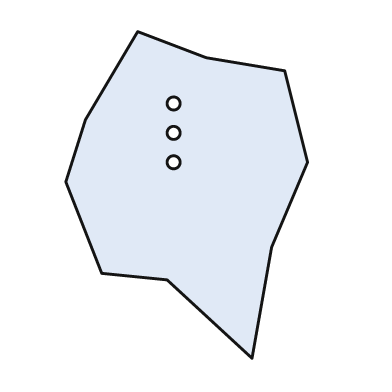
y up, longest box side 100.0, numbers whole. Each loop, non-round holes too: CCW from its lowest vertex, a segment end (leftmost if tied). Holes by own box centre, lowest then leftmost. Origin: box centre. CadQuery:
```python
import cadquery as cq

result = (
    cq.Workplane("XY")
    .moveTo(20.0, -50.0)
    .lineTo(26.0, -16.0)
    .lineTo(37.0, 10.0)
    .lineTo(30.0, 38.0)
    .lineTo(6.0, 42.0)
    .lineTo(-15.0, 50.0)
    .lineTo(-31.0, 23.0)
    .lineTo(-37.0, 4.0)
    .lineTo(-26.0, -24.0)
    .lineTo(-6.0, -26.0)
    .close()
    .moveTo(-4.0, 10.0)
    .circle(2.0)
    .moveTo(-4.0, 19.0)
    .circle(2.0)
    .moveTo(-4.0, 28.0)
    .circle(2.0)
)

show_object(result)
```